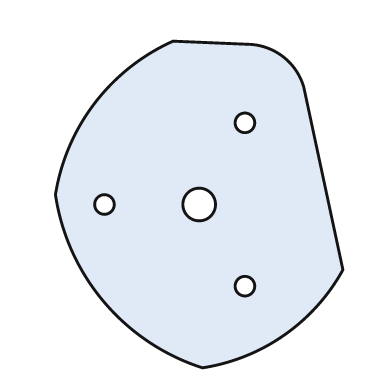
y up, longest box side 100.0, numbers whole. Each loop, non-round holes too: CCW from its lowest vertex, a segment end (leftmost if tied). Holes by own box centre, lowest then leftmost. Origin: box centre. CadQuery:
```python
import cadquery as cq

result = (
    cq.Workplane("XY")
    .moveTo(1.0, -50.0)
    .threePointArc((26.0, -40.0), (44.0, -20.0))
    .lineTo(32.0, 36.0)
    .threePointArc((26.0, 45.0), (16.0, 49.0))
    .lineTo(-8.0, 50.0)
    .threePointArc((-32.0, 31.0), (-44.0, 3.0))
    .threePointArc((-29.0, -30.0), (1.0, -50.0))
    .close()
    .moveTo(14.0, -25.0)
    .circle(3.0)
    .moveTo(-29.0, 0.0)
    .circle(3.0)
    .moveTo(0.0, 0.0)
    .circle(5.0)
    .moveTo(14.0, 25.0)
    .circle(3.0)
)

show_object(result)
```